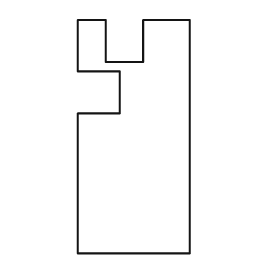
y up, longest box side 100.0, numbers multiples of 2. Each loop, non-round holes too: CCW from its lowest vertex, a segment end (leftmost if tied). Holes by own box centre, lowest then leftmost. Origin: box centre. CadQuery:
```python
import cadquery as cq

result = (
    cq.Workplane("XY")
    .moveTo(-24.0, -50.0)
    .lineTo(24.0, -50.0)
    .lineTo(24.0, 50.0)
    .lineTo(4.0, 50.0)
    .lineTo(4.0, 32.0)
    .lineTo(-12.0, 32.0)
    .lineTo(-12.0, 50.0)
    .lineTo(-24.0, 50.0)
    .lineTo(-24.0, 28.0)
    .lineTo(-6.0, 28.0)
    .lineTo(-6.0, 10.0)
    .lineTo(-24.0, 10.0)
    .close()
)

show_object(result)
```